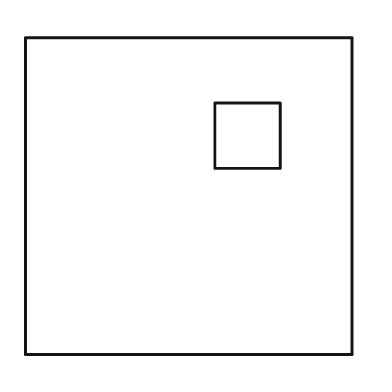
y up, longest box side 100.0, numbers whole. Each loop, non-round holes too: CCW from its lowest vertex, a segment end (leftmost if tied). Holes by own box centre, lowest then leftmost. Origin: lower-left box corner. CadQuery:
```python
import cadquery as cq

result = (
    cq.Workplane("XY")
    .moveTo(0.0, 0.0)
    .lineTo(100.0, 0.0)
    .lineTo(100.0, 97.0)
    .lineTo(0.0, 97.0)
    .close()
    .moveTo(58.0, 57.0)
    .lineTo(78.0, 57.0)
    .lineTo(78.0, 77.0)
    .lineTo(58.0, 77.0)
    .close()
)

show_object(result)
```